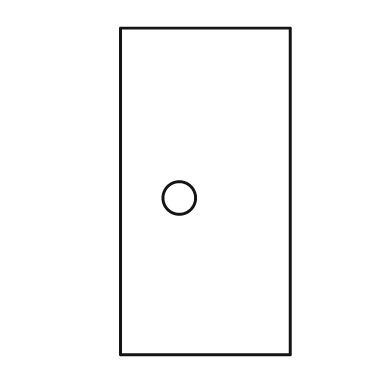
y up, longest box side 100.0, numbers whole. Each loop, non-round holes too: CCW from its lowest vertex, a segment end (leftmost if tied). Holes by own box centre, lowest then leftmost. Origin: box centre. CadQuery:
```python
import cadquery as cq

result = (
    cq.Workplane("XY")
    .moveTo(-26.0, -50.0)
    .lineTo(26.0, -50.0)
    .lineTo(26.0, 50.0)
    .lineTo(-26.0, 50.0)
    .close()
    .moveTo(-8.0, -2.0)
    .circle(5.0)
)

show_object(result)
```